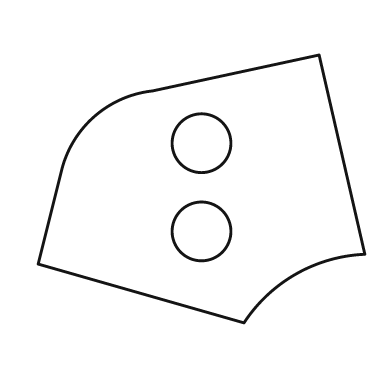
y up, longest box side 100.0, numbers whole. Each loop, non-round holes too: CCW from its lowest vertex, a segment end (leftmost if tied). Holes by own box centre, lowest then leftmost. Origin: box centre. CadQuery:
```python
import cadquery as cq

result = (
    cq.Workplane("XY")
    .moveTo(13.0, -41.0)
    .threePointArc((29.0, -26.0), (50.0, -20.0))
    .lineTo(36.0, 41.0)
    .lineTo(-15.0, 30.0)
    .threePointArc((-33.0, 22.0), (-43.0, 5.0))
    .lineTo(-50.0, -23.0)
    .close()
    .moveTo(0.0, -13.0)
    .circle(9.0)
    .moveTo(0.0, 14.0)
    .circle(9.0)
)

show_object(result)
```